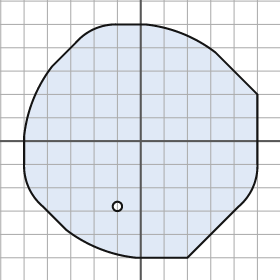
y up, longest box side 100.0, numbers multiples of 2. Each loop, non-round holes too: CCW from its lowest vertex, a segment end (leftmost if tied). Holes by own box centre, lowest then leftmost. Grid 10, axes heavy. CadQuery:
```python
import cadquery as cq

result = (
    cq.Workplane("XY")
    .moveTo(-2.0, -50.0)
    .lineTo(20.0, -50.0)
    .lineTo(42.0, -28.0)
    .threePointArc((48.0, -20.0), (50.0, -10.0))
    .lineTo(50.0, 20.0)
    .lineTo(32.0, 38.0)
    .threePointArc((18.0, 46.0), (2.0, 50.0))
    .lineTo(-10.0, 50.0)
    .threePointArc((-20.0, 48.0), (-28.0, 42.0))
    .lineTo(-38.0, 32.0)
    .threePointArc((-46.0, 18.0), (-50.0, 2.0))
    .lineTo(-50.0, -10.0)
    .threePointArc((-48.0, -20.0), (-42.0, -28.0))
    .lineTo(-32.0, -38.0)
    .threePointArc((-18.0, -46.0), (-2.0, -50.0))
    .close()
    .moveTo(-10.0, -28.0)
    .circle(2.0)
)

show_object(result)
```